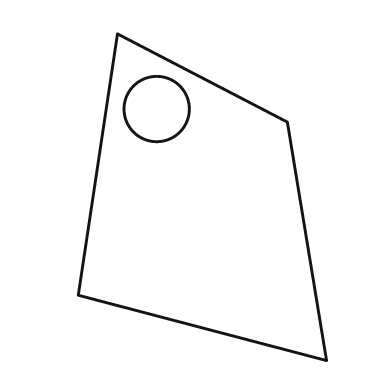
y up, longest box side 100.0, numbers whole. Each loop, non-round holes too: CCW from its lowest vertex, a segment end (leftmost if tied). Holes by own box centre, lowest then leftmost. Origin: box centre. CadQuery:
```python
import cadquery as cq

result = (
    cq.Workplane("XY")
    .moveTo(38.0, -50.0)
    .lineTo(26.0, 23.0)
    .lineTo(-26.0, 50.0)
    .lineTo(-38.0, -30.0)
    .close()
    .moveTo(-14.0, 27.0)
    .circle(10.0)
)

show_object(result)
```